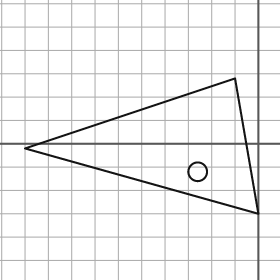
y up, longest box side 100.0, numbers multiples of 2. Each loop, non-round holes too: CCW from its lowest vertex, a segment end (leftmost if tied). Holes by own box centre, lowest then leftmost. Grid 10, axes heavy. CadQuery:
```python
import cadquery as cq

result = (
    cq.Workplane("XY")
    .moveTo(0.0, -30.0)
    .lineTo(-10.0, 28.0)
    .lineTo(-100.0, -2.0)
    .close()
    .moveTo(-26.0, -12.0)
    .circle(4.0)
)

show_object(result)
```